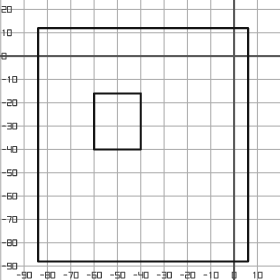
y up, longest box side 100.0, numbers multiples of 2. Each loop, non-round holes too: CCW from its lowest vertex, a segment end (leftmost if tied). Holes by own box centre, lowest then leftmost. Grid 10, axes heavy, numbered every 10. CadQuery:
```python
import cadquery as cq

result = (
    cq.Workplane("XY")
    .moveTo(-84.0, -88.0)
    .lineTo(6.0, -88.0)
    .lineTo(6.0, 12.0)
    .lineTo(-84.0, 12.0)
    .close()
    .moveTo(-60.0, -40.0)
    .lineTo(-40.0, -40.0)
    .lineTo(-40.0, -16.0)
    .lineTo(-60.0, -16.0)
    .close()
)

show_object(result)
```